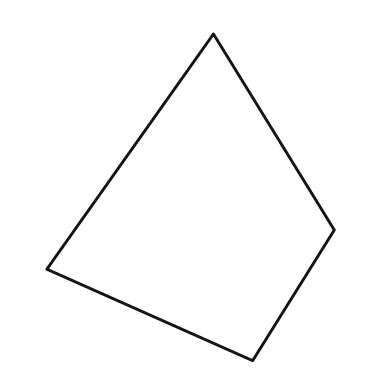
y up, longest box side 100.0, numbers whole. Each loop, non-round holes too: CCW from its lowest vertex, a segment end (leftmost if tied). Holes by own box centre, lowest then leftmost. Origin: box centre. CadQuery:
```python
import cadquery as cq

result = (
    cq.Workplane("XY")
    .moveTo(19.0, -50.0)
    .lineTo(44.0, -10.0)
    .lineTo(7.0, 50.0)
    .lineTo(-44.0, -22.0)
    .close()
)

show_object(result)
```